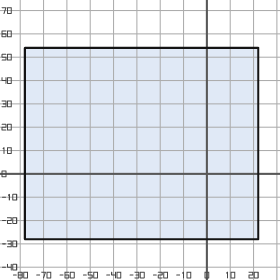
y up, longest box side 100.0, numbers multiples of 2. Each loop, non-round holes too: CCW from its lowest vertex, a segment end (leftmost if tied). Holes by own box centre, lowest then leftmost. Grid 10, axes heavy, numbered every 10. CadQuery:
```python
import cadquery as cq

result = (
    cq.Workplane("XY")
    .moveTo(-78.0, -28.0)
    .lineTo(22.0, -28.0)
    .lineTo(22.0, 54.0)
    .lineTo(-78.0, 54.0)
    .close()
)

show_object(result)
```